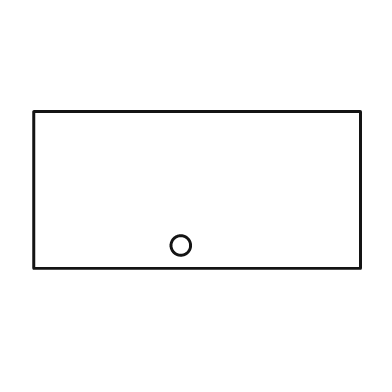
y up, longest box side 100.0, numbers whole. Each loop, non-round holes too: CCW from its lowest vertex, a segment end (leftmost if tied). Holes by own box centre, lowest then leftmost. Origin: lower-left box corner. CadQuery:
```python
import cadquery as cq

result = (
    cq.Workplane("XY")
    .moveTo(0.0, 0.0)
    .lineTo(100.0, 0.0)
    .lineTo(100.0, 48.0)
    .lineTo(0.0, 48.0)
    .close()
    .moveTo(45.0, 7.0)
    .circle(3.0)
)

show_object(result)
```